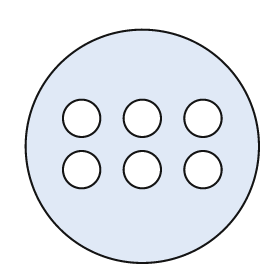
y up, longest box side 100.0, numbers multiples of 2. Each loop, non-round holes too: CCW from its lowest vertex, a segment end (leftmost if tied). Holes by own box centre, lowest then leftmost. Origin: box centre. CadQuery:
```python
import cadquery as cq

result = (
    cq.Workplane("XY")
    .moveTo(0.0, 0.0)
    .circle(50.0)
    .moveTo(-26.0, -10.0)
    .circle(8.0)
    .moveTo(0.0, -10.0)
    .circle(8.0)
    .moveTo(26.0, -10.0)
    .circle(8.0)
    .moveTo(-26.0, 12.0)
    .circle(8.0)
    .moveTo(0.0, 12.0)
    .circle(8.0)
    .moveTo(26.0, 12.0)
    .circle(8.0)
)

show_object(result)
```